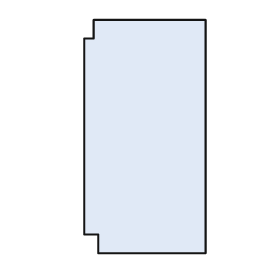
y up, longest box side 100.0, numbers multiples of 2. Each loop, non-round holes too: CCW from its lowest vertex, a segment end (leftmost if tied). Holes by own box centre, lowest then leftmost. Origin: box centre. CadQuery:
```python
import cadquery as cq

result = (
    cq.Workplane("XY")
    .moveTo(-20.0, -50.0)
    .lineTo(26.0, -50.0)
    .lineTo(26.0, 50.0)
    .lineTo(-22.0, 50.0)
    .lineTo(-22.0, 42.0)
    .lineTo(-26.0, 42.0)
    .lineTo(-26.0, -42.0)
    .lineTo(-20.0, -42.0)
    .close()
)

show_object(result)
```